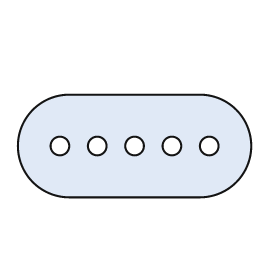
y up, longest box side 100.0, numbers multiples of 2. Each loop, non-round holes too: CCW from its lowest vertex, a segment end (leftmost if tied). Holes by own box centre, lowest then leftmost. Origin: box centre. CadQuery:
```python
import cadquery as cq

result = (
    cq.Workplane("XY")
    .moveTo(-28.0, -22.0)
    .lineTo(28.0, -22.0)
    .threePointArc((50.0, 0.0), (28.0, 22.0))
    .lineTo(-28.0, 22.0)
    .threePointArc((-50.0, 0.0), (-28.0, -22.0))
    .close()
    .moveTo(-32.0, 0.0)
    .circle(4.0)
    .moveTo(-16.0, 0.0)
    .circle(4.0)
    .moveTo(0.0, 0.0)
    .circle(4.0)
    .moveTo(16.0, 0.0)
    .circle(4.0)
    .moveTo(32.0, 0.0)
    .circle(4.0)
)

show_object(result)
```